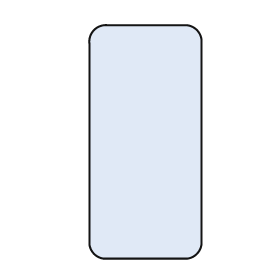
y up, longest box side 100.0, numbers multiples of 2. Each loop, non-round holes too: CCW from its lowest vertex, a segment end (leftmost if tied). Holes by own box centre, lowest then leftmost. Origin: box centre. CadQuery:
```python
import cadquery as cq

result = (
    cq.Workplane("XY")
    .moveTo(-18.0, -50.0)
    .lineTo(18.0, -50.0)
    .threePointArc((22.0, -48.0), (24.0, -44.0))
    .lineTo(24.0, 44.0)
    .threePointArc((22.0, 48.0), (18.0, 50.0))
    .lineTo(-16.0, 50.0)
    .threePointArc((-22.0, 48.0), (-24.0, 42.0))
    .lineTo(-24.0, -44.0)
    .threePointArc((-22.0, -48.0), (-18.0, -50.0))
    .close()
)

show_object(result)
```